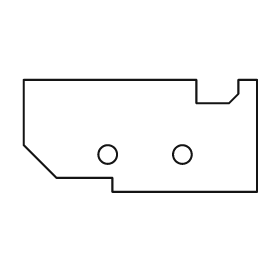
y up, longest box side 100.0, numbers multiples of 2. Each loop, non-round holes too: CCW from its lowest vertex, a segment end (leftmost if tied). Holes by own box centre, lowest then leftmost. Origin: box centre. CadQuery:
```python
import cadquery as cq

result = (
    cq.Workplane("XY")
    .moveTo(-12.0, -24.0)
    .lineTo(50.0, -24.0)
    .lineTo(50.0, 24.0)
    .lineTo(42.0, 24.0)
    .lineTo(42.0, 18.0)
    .lineTo(38.0, 14.0)
    .lineTo(24.0, 14.0)
    .lineTo(24.0, 24.0)
    .lineTo(-50.0, 24.0)
    .lineTo(-50.0, -4.0)
    .lineTo(-36.0, -18.0)
    .lineTo(-12.0, -18.0)
    .close()
    .moveTo(-14.0, -8.0)
    .circle(4.0)
    .moveTo(18.0, -8.0)
    .circle(4.0)
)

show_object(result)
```